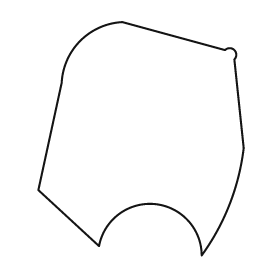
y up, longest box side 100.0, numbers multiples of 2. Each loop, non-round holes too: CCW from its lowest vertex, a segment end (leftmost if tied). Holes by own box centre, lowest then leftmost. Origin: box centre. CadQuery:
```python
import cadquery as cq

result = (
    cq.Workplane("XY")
    .moveTo(26.0, -50.0)
    .threePointArc((38.0, -28.0), (44.0, -4.0))
    .lineTo(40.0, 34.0)
    .threePointArc((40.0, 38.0), (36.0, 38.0))
    .lineTo(-8.0, 50.0)
    .threePointArc((-26.0, 42.0), (-34.0, 24.0))
    .lineTo(-44.0, -22.0)
    .lineTo(-18.0, -46.0)
    .threePointArc((6.0, -28.0), (26.0, -50.0))
    .close()
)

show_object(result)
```